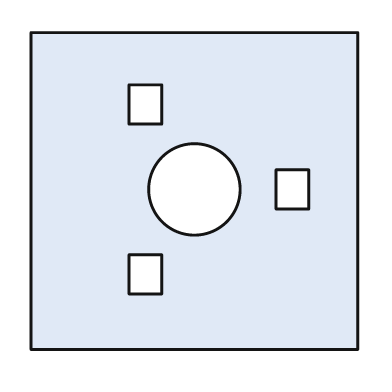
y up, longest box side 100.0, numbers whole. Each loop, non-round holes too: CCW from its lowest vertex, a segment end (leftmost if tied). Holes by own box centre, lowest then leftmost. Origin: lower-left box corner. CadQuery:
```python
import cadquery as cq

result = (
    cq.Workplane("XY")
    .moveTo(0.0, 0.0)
    .lineTo(100.0, 0.0)
    .lineTo(100.0, 97.0)
    .lineTo(0.0, 97.0)
    .close()
    .moveTo(30.0, 17.0)
    .lineTo(40.0, 17.0)
    .lineTo(40.0, 29.0)
    .lineTo(30.0, 29.0)
    .close()
    .moveTo(50.0, 49.0)
    .circle(14.0)
    .moveTo(75.0, 43.0)
    .lineTo(85.0, 43.0)
    .lineTo(85.0, 55.0)
    .lineTo(75.0, 55.0)
    .close()
    .moveTo(30.0, 69.0)
    .lineTo(40.0, 69.0)
    .lineTo(40.0, 81.0)
    .lineTo(30.0, 81.0)
    .close()
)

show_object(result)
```